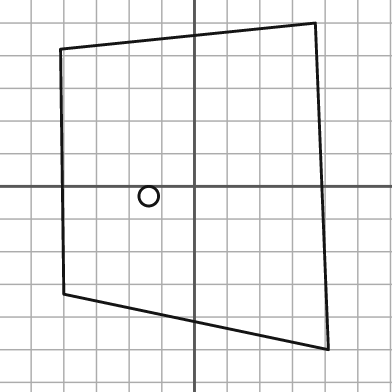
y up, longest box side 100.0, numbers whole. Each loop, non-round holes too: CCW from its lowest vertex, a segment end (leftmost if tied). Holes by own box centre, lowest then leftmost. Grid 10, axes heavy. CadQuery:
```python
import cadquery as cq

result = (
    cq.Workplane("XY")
    .moveTo(41.0, -50.0)
    .lineTo(37.0, 50.0)
    .lineTo(-41.0, 42.0)
    .lineTo(-40.0, -33.0)
    .close()
    .moveTo(-14.0, -3.0)
    .circle(3.0)
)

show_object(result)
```